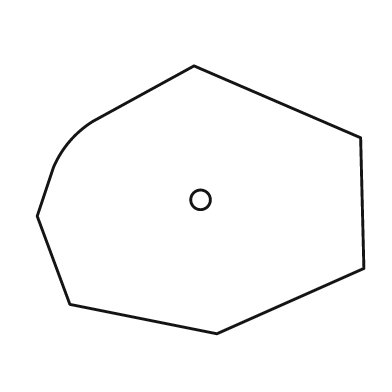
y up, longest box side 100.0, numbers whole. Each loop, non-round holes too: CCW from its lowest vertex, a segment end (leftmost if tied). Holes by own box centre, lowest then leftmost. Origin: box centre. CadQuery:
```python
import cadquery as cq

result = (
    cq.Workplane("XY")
    .moveTo(5.0, -41.0)
    .lineTo(50.0, -21.0)
    .lineTo(49.0, 19.0)
    .lineTo(-2.0, 41.0)
    .lineTo(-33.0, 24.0)
    .threePointArc((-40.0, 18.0), (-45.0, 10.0))
    .lineTo(-50.0, -5.0)
    .lineTo(-40.0, -32.0)
    .close()
    .moveTo(0.0, 0.0)
    .circle(3.0)
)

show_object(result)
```